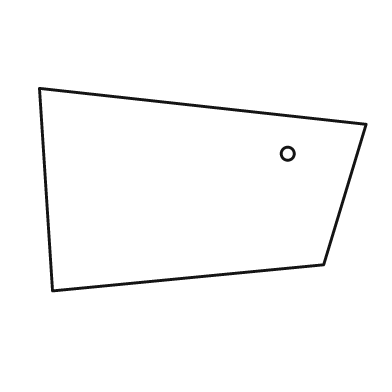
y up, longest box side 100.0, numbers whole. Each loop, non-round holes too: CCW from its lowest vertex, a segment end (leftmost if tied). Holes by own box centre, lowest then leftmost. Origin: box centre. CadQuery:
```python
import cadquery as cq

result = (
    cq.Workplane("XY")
    .moveTo(-46.0, -31.0)
    .lineTo(37.0, -23.0)
    .lineTo(50.0, 20.0)
    .lineTo(-50.0, 31.0)
    .close()
    .moveTo(26.0, 11.0)
    .circle(2.0)
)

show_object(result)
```